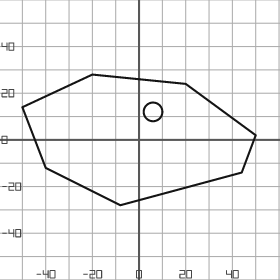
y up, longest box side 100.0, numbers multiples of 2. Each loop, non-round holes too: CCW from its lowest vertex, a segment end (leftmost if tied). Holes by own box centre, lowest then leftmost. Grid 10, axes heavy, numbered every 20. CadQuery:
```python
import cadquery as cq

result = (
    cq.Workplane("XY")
    .moveTo(-8.0, -28.0)
    .lineTo(44.0, -14.0)
    .lineTo(50.0, 2.0)
    .lineTo(20.0, 24.0)
    .lineTo(-20.0, 28.0)
    .lineTo(-50.0, 14.0)
    .lineTo(-40.0, -12.0)
    .close()
    .moveTo(6.0, 12.0)
    .circle(4.0)
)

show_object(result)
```